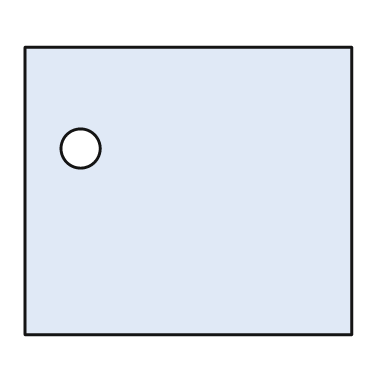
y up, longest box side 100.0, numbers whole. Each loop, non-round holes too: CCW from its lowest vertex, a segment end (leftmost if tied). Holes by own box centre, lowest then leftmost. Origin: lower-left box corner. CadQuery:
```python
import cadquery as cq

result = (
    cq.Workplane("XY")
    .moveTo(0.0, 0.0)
    .lineTo(100.0, 0.0)
    .lineTo(100.0, 88.0)
    .lineTo(0.0, 88.0)
    .close()
    .moveTo(17.0, 57.0)
    .circle(6.0)
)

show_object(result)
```